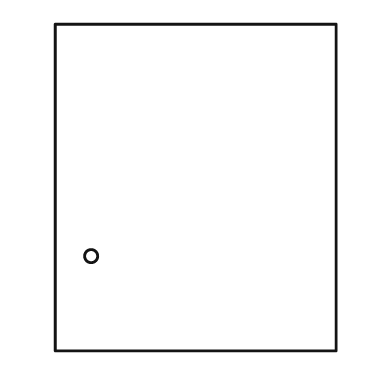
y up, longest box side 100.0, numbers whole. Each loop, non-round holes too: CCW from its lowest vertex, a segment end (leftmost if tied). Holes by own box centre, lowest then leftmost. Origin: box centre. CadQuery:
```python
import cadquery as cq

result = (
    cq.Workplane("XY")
    .moveTo(-43.0, -50.0)
    .lineTo(43.0, -50.0)
    .lineTo(43.0, 50.0)
    .lineTo(-43.0, 50.0)
    .close()
    .moveTo(-32.0, -21.0)
    .circle(2.0)
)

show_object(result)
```